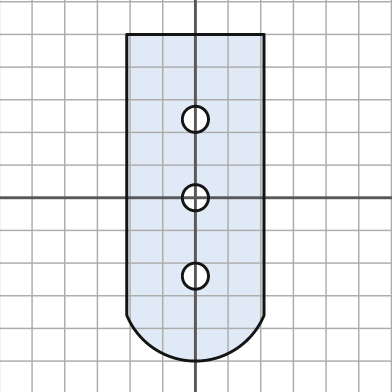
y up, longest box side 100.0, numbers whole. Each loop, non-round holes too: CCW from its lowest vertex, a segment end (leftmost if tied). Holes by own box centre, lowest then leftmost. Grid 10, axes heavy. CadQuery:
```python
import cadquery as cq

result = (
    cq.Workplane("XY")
    .moveTo(-21.0, -36.0)
    .threePointArc((0.0, -50.0), (21.0, -36.0))
    .lineTo(21.0, 50.0)
    .lineTo(-21.0, 50.0)
    .close()
    .moveTo(0.0, -24.0)
    .circle(4.0)
    .moveTo(0.0, 0.0)
    .circle(4.0)
    .moveTo(0.0, 24.0)
    .circle(4.0)
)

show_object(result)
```